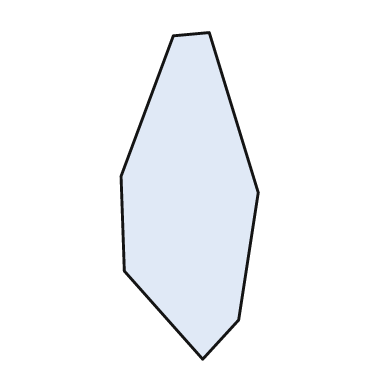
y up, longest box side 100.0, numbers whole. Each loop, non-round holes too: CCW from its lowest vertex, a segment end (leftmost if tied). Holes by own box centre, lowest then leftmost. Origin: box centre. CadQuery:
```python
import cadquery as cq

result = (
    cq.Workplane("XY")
    .moveTo(4.0, -50.0)
    .lineTo(15.0, -38.0)
    .lineTo(21.0, 1.0)
    .lineTo(6.0, 50.0)
    .lineTo(-5.0, 49.0)
    .lineTo(-21.0, 6.0)
    .lineTo(-20.0, -23.0)
    .close()
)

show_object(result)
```